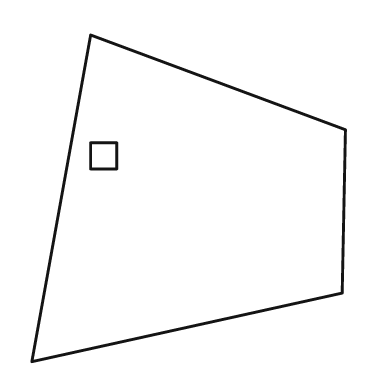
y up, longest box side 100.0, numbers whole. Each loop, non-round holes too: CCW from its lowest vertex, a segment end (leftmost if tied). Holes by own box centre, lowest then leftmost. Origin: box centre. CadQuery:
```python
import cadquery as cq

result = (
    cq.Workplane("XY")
    .moveTo(-48.0, -50.0)
    .lineTo(47.0, -29.0)
    .lineTo(48.0, 21.0)
    .lineTo(-30.0, 50.0)
    .close()
    .moveTo(-30.0, 9.0)
    .lineTo(-22.0, 9.0)
    .lineTo(-22.0, 17.0)
    .lineTo(-30.0, 17.0)
    .close()
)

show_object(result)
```